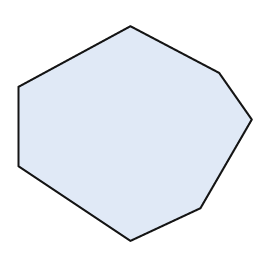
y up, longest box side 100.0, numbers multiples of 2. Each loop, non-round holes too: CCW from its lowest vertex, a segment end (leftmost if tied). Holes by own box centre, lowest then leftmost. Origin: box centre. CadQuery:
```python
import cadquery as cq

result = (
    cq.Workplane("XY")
    .moveTo(-2.0, -46.0)
    .lineTo(28.0, -32.0)
    .lineTo(50.0, 6.0)
    .lineTo(36.0, 26.0)
    .lineTo(-2.0, 46.0)
    .lineTo(-50.0, 20.0)
    .lineTo(-50.0, -14.0)
    .close()
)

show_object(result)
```